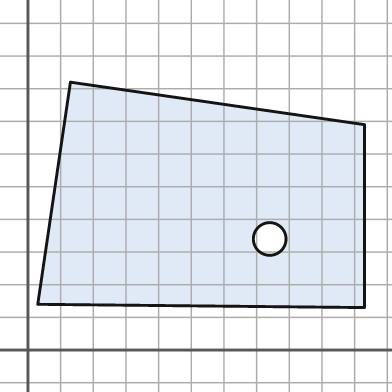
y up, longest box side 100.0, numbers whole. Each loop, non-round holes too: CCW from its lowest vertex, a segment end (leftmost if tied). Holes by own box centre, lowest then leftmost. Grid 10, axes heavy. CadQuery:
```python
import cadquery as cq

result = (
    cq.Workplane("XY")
    .moveTo(103.0, 13.0)
    .lineTo(103.0, 69.0)
    .lineTo(13.0, 82.0)
    .lineTo(3.0, 14.0)
    .close()
    .moveTo(74.0, 34.0)
    .circle(5.0)
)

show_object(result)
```